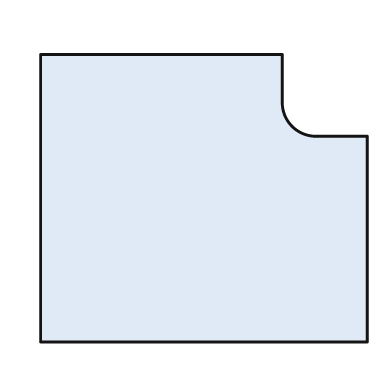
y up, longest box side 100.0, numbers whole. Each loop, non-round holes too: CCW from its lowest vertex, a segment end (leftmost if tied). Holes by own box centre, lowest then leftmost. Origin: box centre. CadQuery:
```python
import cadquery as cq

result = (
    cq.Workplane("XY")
    .moveTo(-50.0, -44.0)
    .lineTo(50.0, -44.0)
    .lineTo(50.0, 19.0)
    .lineTo(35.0, 19.0)
    .threePointArc((27.0, 22.0), (24.0, 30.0))
    .lineTo(24.0, 44.0)
    .lineTo(-50.0, 44.0)
    .close()
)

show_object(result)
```